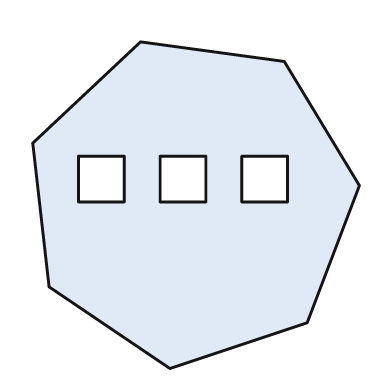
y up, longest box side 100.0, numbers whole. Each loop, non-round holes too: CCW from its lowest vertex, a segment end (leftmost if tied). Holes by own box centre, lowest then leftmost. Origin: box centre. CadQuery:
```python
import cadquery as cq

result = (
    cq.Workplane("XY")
    .moveTo(-8.0, -50.0)
    .lineTo(34.0, -36.0)
    .lineTo(50.0, 6.0)
    .lineTo(27.0, 44.0)
    .lineTo(-17.0, 50.0)
    .lineTo(-50.0, 19.0)
    .lineTo(-45.0, -25.0)
    .close()
    .moveTo(-36.0, 1.0)
    .lineTo(-22.0, 1.0)
    .lineTo(-22.0, 15.0)
    .lineTo(-36.0, 15.0)
    .close()
    .moveTo(-11.0, 1.0)
    .lineTo(3.0, 1.0)
    .lineTo(3.0, 15.0)
    .lineTo(-11.0, 15.0)
    .close()
    .moveTo(14.0, 1.0)
    .lineTo(28.0, 1.0)
    .lineTo(28.0, 15.0)
    .lineTo(14.0, 15.0)
    .close()
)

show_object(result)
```